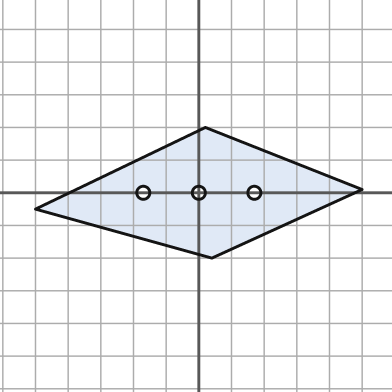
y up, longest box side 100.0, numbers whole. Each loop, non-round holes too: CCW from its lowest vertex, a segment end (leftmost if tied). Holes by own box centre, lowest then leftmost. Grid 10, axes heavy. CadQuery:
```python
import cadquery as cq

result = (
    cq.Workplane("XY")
    .moveTo(4.0, -20.0)
    .lineTo(50.0, 1.0)
    .lineTo(2.0, 20.0)
    .lineTo(-50.0, -5.0)
    .close()
    .moveTo(-17.0, 0.0)
    .circle(2.0)
    .moveTo(0.0, 0.0)
    .circle(2.0)
    .moveTo(17.0, 0.0)
    .circle(2.0)
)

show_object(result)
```